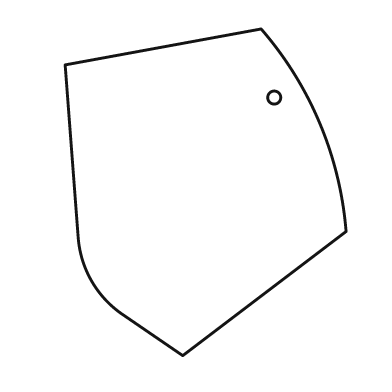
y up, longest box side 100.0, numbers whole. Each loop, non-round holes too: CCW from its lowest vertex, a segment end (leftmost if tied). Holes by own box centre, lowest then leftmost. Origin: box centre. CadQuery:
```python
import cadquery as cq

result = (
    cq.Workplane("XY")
    .moveTo(-7.0, -50.0)
    .lineTo(43.0, -12.0)
    .threePointArc((35.0, 21.0), (17.0, 50.0))
    .lineTo(-43.0, 39.0)
    .lineTo(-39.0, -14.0)
    .threePointArc((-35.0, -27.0), (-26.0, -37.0))
    .close()
    .moveTo(21.0, 29.0)
    .circle(2.0)
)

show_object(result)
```